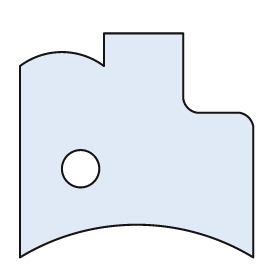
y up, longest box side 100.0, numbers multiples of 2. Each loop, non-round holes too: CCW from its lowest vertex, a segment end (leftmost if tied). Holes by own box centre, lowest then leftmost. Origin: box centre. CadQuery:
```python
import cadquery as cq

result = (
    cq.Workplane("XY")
    .moveTo(-50.0, -48.0)
    .threePointArc((0.0, -34.0), (50.0, -48.0))
    .lineTo(50.0, 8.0)
    .threePointArc((48.0, 12.0), (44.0, 14.0))
    .lineTo(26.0, 14.0)
    .threePointArc((22.0, 16.0), (20.0, 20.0))
    .lineTo(20.0, 48.0)
    .lineTo(-14.0, 48.0)
    .lineTo(-14.0, 34.0)
    .threePointArc((-32.0, 40.0), (-50.0, 34.0))
    .close()
    .moveTo(-24.0, -10.0)
    .circle(8.0)
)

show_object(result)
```